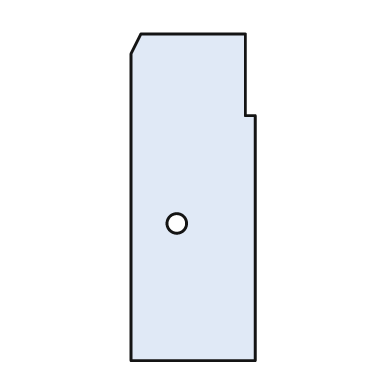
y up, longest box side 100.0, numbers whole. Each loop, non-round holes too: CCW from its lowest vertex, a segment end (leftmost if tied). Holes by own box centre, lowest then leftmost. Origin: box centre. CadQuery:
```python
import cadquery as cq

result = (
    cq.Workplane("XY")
    .moveTo(-19.0, -50.0)
    .lineTo(19.0, -50.0)
    .lineTo(19.0, 25.0)
    .lineTo(16.0, 25.0)
    .lineTo(16.0, 50.0)
    .lineTo(-16.0, 50.0)
    .lineTo(-19.0, 44.0)
    .close()
    .moveTo(-5.0, -8.0)
    .circle(3.0)
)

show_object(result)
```